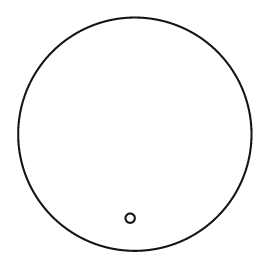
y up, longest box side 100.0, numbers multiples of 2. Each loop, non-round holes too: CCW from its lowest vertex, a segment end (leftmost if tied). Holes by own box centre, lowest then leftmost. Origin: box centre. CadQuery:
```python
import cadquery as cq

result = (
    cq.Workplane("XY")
    .moveTo(0.0, 0.0)
    .circle(50.0)
    .moveTo(-2.0, -36.0)
    .circle(2.0)
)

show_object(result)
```